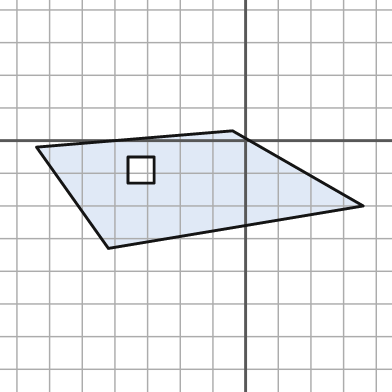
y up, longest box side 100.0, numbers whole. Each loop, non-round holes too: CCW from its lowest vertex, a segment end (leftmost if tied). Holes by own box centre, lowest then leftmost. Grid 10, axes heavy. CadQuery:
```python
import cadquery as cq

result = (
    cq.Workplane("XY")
    .moveTo(-42.0, -33.0)
    .lineTo(36.0, -20.0)
    .lineTo(-4.0, 3.0)
    .lineTo(-64.0, -2.0)
    .close()
    .moveTo(-36.0, -13.0)
    .lineTo(-28.0, -13.0)
    .lineTo(-28.0, -5.0)
    .lineTo(-36.0, -5.0)
    .close()
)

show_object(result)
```